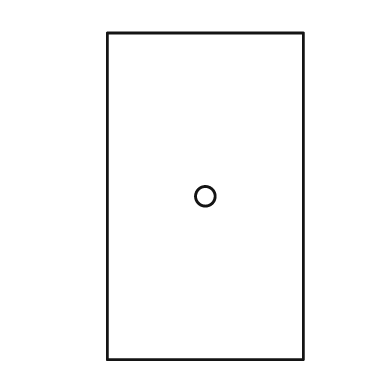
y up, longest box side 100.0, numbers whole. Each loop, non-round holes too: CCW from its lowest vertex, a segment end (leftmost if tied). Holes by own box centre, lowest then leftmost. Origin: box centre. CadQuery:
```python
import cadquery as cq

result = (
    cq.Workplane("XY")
    .moveTo(-30.0, -50.0)
    .lineTo(30.0, -50.0)
    .lineTo(30.0, 50.0)
    .lineTo(-30.0, 50.0)
    .close()
    .moveTo(0.0, 0.0)
    .circle(3.0)
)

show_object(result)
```